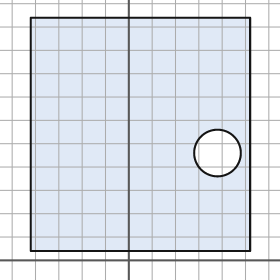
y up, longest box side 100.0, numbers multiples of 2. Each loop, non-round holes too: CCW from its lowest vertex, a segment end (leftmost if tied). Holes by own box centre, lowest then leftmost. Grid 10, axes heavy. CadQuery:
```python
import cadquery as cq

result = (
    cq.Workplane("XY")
    .moveTo(-42.0, 4.0)
    .lineTo(52.0, 4.0)
    .lineTo(52.0, 104.0)
    .lineTo(-42.0, 104.0)
    .close()
    .moveTo(38.0, 46.0)
    .circle(10.0)
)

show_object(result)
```